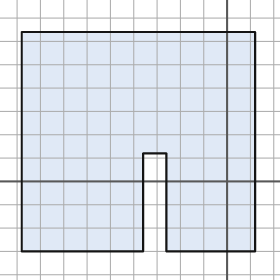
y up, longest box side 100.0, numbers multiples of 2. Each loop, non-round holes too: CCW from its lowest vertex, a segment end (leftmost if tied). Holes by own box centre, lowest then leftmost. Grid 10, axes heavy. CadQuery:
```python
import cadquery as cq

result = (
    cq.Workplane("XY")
    .moveTo(-88.0, -30.0)
    .lineTo(-36.0, -30.0)
    .lineTo(-36.0, 12.0)
    .lineTo(-26.0, 12.0)
    .lineTo(-26.0, -30.0)
    .lineTo(12.0, -30.0)
    .lineTo(12.0, 64.0)
    .lineTo(-88.0, 64.0)
    .close()
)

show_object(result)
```